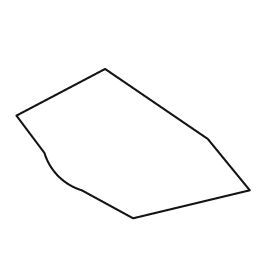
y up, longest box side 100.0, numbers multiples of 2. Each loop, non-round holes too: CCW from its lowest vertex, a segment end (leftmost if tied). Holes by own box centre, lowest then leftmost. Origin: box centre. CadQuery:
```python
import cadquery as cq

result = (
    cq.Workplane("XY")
    .moveTo(0.0, -32.0)
    .lineTo(50.0, -20.0)
    .lineTo(32.0, 2.0)
    .lineTo(-12.0, 32.0)
    .lineTo(-50.0, 12.0)
    .lineTo(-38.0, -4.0)
    .threePointArc((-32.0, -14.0), (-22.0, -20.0))
    .close()
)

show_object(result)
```